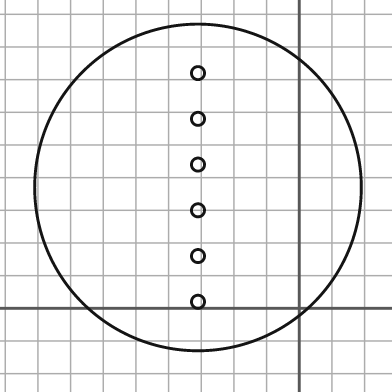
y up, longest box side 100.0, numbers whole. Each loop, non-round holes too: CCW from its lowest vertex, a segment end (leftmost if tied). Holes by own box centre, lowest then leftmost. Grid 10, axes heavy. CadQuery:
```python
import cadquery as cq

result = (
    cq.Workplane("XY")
    .moveTo(-31.0, 37.0)
    .circle(50.0)
    .moveTo(-31.0, 2.0)
    .circle(2.0)
    .moveTo(-31.0, 16.0)
    .circle(2.0)
    .moveTo(-31.0, 30.0)
    .circle(2.0)
    .moveTo(-31.0, 44.0)
    .circle(2.0)
    .moveTo(-31.0, 58.0)
    .circle(2.0)
    .moveTo(-31.0, 72.0)
    .circle(2.0)
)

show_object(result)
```